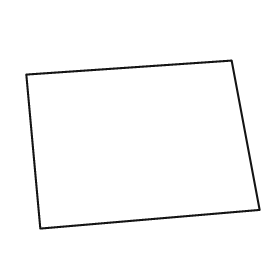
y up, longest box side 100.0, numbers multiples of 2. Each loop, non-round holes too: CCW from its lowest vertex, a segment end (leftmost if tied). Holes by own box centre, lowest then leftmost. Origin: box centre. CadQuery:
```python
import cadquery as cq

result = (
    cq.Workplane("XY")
    .moveTo(-44.0, -36.0)
    .lineTo(50.0, -28.0)
    .lineTo(38.0, 36.0)
    .lineTo(-50.0, 30.0)
    .close()
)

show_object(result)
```